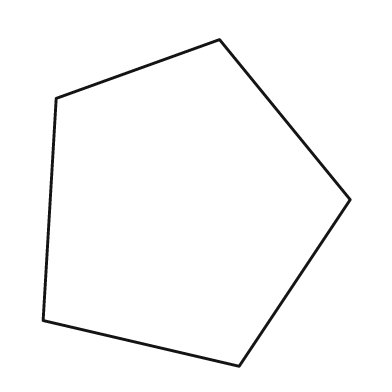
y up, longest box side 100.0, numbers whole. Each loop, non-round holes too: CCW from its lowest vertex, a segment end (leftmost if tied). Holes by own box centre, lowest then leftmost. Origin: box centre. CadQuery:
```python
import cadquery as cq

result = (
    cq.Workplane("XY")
    .moveTo(13.0, -50.0)
    .lineTo(47.0, 1.0)
    .lineTo(7.0, 50.0)
    .lineTo(-43.0, 32.0)
    .lineTo(-47.0, -36.0)
    .close()
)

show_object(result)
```